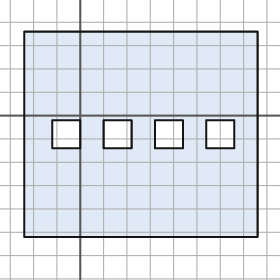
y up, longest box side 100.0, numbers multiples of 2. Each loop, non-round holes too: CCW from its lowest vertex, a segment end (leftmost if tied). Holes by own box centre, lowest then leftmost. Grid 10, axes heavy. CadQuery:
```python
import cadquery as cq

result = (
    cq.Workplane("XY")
    .moveTo(-24.0, -52.0)
    .lineTo(76.0, -52.0)
    .lineTo(76.0, 36.0)
    .lineTo(-24.0, 36.0)
    .close()
    .moveTo(-12.0, -14.0)
    .lineTo(0.0, -14.0)
    .lineTo(0.0, -2.0)
    .lineTo(-12.0, -2.0)
    .close()
    .moveTo(10.0, -14.0)
    .lineTo(22.0, -14.0)
    .lineTo(22.0, -2.0)
    .lineTo(10.0, -2.0)
    .close()
    .moveTo(32.0, -14.0)
    .lineTo(44.0, -14.0)
    .lineTo(44.0, -2.0)
    .lineTo(32.0, -2.0)
    .close()
    .moveTo(54.0, -14.0)
    .lineTo(66.0, -14.0)
    .lineTo(66.0, -2.0)
    .lineTo(54.0, -2.0)
    .close()
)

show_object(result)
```